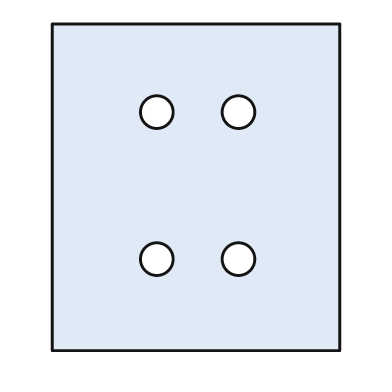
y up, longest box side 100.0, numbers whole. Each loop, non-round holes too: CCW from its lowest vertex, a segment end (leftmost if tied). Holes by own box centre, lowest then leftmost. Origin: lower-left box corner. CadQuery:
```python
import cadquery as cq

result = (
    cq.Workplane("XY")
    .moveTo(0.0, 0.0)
    .lineTo(88.0, 0.0)
    .lineTo(88.0, 100.0)
    .lineTo(0.0, 100.0)
    .close()
    .moveTo(32.0, 28.0)
    .circle(5.0)
    .moveTo(57.0, 28.0)
    .circle(5.0)
    .moveTo(32.0, 73.0)
    .circle(5.0)
    .moveTo(57.0, 73.0)
    .circle(5.0)
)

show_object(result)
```